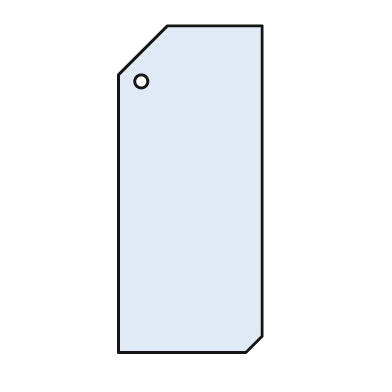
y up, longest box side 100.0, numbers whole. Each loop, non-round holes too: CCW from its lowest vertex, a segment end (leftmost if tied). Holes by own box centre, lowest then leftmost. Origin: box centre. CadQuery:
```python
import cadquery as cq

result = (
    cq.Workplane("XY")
    .moveTo(-22.0, -50.0)
    .lineTo(17.0, -50.0)
    .lineTo(22.0, -45.0)
    .lineTo(22.0, 50.0)
    .lineTo(-7.0, 50.0)
    .lineTo(-22.0, 35.0)
    .close()
    .moveTo(-15.0, 33.0)
    .circle(2.0)
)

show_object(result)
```